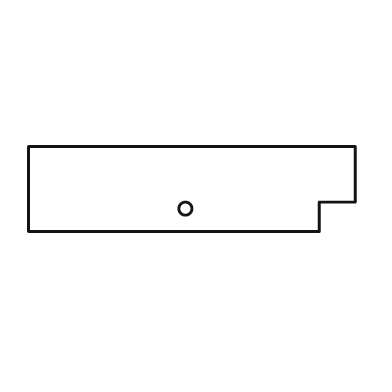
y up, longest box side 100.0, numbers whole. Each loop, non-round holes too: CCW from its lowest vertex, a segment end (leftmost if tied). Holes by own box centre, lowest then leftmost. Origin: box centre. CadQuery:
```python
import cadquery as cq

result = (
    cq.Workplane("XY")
    .moveTo(-50.0, -13.0)
    .lineTo(39.0, -13.0)
    .lineTo(39.0, -4.0)
    .lineTo(50.0, -4.0)
    .lineTo(50.0, 13.0)
    .lineTo(-50.0, 13.0)
    .close()
    .moveTo(-2.0, -6.0)
    .circle(2.0)
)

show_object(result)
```